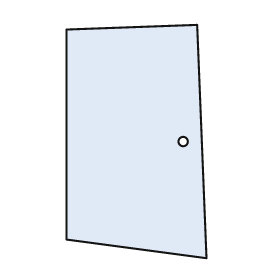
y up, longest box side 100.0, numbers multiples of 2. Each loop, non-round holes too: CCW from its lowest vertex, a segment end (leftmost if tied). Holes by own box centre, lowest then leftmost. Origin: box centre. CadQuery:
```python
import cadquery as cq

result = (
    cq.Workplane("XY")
    .moveTo(30.0, -50.0)
    .lineTo(26.0, 50.0)
    .lineTo(-30.0, 48.0)
    .lineTo(-30.0, -42.0)
    .close()
    .moveTo(20.0, 0.0)
    .circle(2.0)
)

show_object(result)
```